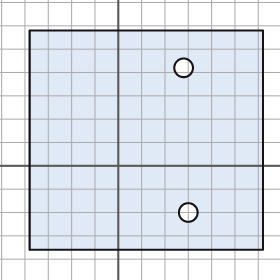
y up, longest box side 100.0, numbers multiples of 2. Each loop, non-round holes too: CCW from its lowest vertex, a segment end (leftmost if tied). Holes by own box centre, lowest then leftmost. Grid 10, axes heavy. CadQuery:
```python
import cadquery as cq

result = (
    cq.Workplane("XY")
    .moveTo(-38.0, -36.0)
    .lineTo(62.0, -36.0)
    .lineTo(62.0, 58.0)
    .lineTo(-38.0, 58.0)
    .close()
    .moveTo(30.0, -20.0)
    .circle(4.0)
    .moveTo(28.0, 42.0)
    .circle(4.0)
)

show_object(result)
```